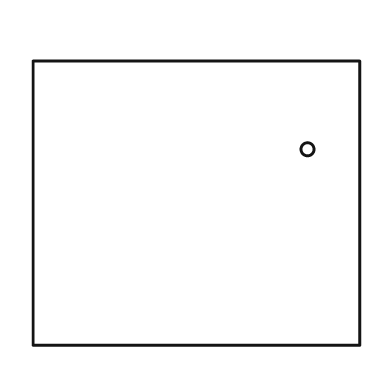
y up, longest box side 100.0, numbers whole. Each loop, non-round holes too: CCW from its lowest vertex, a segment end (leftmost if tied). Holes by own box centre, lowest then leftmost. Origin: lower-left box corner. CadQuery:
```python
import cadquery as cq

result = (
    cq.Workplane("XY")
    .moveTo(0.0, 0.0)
    .lineTo(100.0, 0.0)
    .lineTo(100.0, 87.0)
    .lineTo(0.0, 87.0)
    .close()
    .moveTo(84.0, 60.0)
    .circle(2.0)
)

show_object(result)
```